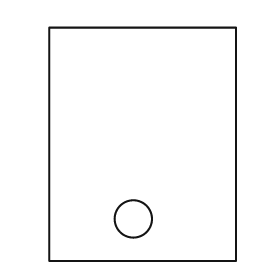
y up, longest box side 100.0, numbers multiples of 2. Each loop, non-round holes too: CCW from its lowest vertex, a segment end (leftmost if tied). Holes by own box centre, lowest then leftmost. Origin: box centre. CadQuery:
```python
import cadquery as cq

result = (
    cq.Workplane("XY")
    .moveTo(-40.0, -50.0)
    .lineTo(40.0, -50.0)
    .lineTo(40.0, 50.0)
    .lineTo(-40.0, 50.0)
    .close()
    .moveTo(-4.0, -32.0)
    .circle(8.0)
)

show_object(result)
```